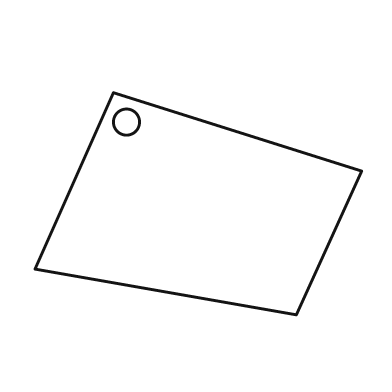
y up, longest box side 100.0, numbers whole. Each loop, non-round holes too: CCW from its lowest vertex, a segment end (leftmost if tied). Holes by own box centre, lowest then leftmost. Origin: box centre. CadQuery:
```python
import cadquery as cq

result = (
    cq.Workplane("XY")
    .moveTo(30.0, -34.0)
    .lineTo(50.0, 10.0)
    .lineTo(-26.0, 34.0)
    .lineTo(-50.0, -20.0)
    .close()
    .moveTo(-22.0, 25.0)
    .circle(4.0)
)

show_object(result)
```